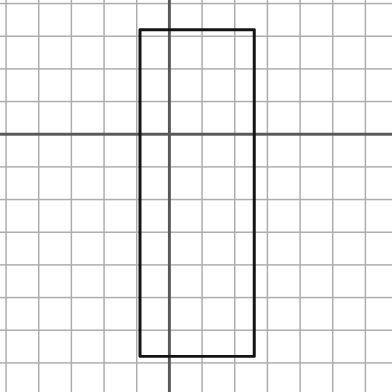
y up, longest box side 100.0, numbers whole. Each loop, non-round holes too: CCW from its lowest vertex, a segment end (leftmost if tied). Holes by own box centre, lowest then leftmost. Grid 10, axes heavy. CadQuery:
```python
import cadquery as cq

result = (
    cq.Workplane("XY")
    .moveTo(-9.0, -68.0)
    .lineTo(26.0, -68.0)
    .lineTo(26.0, 32.0)
    .lineTo(-9.0, 32.0)
    .close()
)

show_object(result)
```